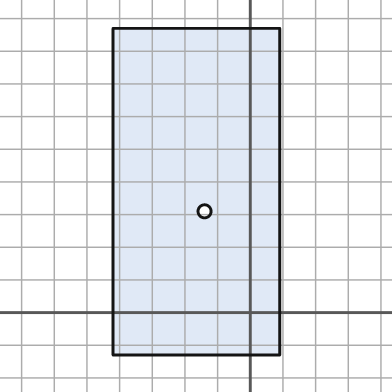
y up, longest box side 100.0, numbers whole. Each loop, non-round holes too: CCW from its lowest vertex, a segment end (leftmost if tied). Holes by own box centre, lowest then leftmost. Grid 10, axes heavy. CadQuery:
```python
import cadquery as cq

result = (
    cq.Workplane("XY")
    .moveTo(-42.0, -13.0)
    .lineTo(9.0, -13.0)
    .lineTo(9.0, 87.0)
    .lineTo(-42.0, 87.0)
    .close()
    .moveTo(-14.0, 31.0)
    .circle(2.0)
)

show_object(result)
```